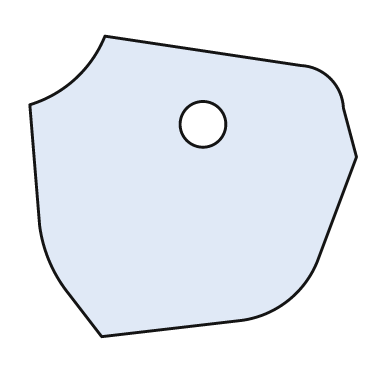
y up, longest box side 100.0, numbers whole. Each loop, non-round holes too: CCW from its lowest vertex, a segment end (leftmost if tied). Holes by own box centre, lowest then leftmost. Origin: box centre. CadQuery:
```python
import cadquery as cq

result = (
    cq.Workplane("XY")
    .moveTo(-28.0, -46.0)
    .lineTo(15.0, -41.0)
    .threePointArc((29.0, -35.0), (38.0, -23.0))
    .lineTo(50.0, 9.0)
    .lineTo(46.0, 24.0)
    .threePointArc((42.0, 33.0), (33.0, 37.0))
    .lineTo(-27.0, 46.0)
    .threePointArc((-36.0, 33.0), (-50.0, 25.0))
    .lineTo(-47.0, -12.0)
    .threePointArc((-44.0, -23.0), (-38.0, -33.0))
    .close()
    .moveTo(3.0, 19.0)
    .circle(7.0)
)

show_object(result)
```